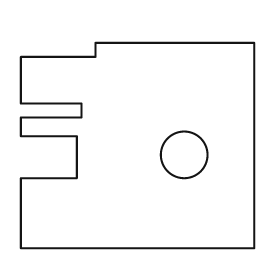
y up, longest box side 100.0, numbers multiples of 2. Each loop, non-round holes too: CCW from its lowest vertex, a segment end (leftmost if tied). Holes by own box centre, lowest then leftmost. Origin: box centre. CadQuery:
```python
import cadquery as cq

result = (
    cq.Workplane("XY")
    .moveTo(-50.0, -44.0)
    .lineTo(50.0, -44.0)
    .lineTo(50.0, 44.0)
    .lineTo(-18.0, 44.0)
    .lineTo(-18.0, 38.0)
    .lineTo(-50.0, 38.0)
    .lineTo(-50.0, 18.0)
    .lineTo(-24.0, 18.0)
    .lineTo(-24.0, 12.0)
    .lineTo(-50.0, 12.0)
    .lineTo(-50.0, 4.0)
    .lineTo(-26.0, 4.0)
    .lineTo(-26.0, -14.0)
    .lineTo(-50.0, -14.0)
    .close()
    .moveTo(20.0, -4.0)
    .circle(10.0)
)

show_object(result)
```